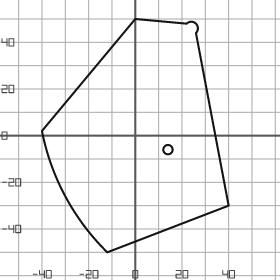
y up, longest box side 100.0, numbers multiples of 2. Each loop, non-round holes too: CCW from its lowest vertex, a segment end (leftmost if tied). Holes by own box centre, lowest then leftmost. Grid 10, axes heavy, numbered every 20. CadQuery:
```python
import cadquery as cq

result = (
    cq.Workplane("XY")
    .moveTo(-12.0, -50.0)
    .lineTo(40.0, -30.0)
    .lineTo(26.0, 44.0)
    .threePointArc((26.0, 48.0), (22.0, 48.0))
    .lineTo(0.0, 50.0)
    .lineTo(-40.0, 2.0)
    .threePointArc((-30.0, -26.0), (-12.0, -50.0))
    .close()
    .moveTo(14.0, -6.0)
    .circle(2.0)
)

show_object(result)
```